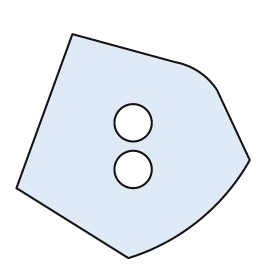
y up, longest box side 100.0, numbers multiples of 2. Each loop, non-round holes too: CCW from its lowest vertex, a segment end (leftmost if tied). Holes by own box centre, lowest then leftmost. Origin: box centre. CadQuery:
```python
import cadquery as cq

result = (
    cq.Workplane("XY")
    .moveTo(-2.0, -48.0)
    .threePointArc((28.0, -32.0), (50.0, -6.0))
    .lineTo(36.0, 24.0)
    .threePointArc((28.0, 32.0), (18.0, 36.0))
    .lineTo(-26.0, 48.0)
    .lineTo(-50.0, -18.0)
    .close()
    .moveTo(0.0, -10.0)
    .circle(8.0)
    .moveTo(0.0, 10.0)
    .circle(8.0)
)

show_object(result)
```